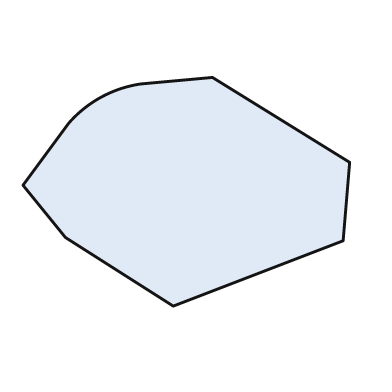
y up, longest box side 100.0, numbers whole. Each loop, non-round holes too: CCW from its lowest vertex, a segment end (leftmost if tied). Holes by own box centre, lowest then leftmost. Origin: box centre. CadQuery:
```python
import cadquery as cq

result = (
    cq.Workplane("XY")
    .moveTo(-4.0, -35.0)
    .lineTo(48.0, -15.0)
    .lineTo(50.0, 9.0)
    .lineTo(8.0, 35.0)
    .lineTo(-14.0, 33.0)
    .threePointArc((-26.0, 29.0), (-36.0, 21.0))
    .lineTo(-50.0, 2.0)
    .lineTo(-37.0, -14.0)
    .close()
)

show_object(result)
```